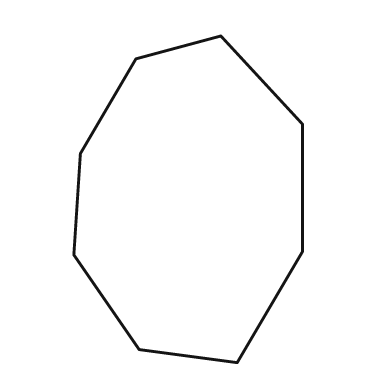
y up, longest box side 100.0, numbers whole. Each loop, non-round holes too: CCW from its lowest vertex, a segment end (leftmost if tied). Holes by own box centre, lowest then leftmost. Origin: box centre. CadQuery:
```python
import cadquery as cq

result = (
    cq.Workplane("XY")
    .moveTo(15.0, -50.0)
    .lineTo(35.0, -16.0)
    .lineTo(35.0, 23.0)
    .lineTo(10.0, 50.0)
    .lineTo(-16.0, 43.0)
    .lineTo(-33.0, 14.0)
    .lineTo(-35.0, -17.0)
    .lineTo(-15.0, -46.0)
    .close()
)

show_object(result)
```